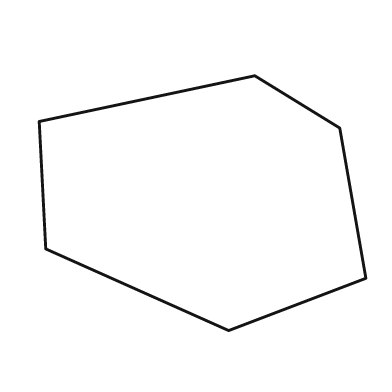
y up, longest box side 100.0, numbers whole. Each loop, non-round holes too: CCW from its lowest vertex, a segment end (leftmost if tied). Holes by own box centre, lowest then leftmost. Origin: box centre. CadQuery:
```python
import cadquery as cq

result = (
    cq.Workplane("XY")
    .moveTo(8.0, -39.0)
    .lineTo(50.0, -23.0)
    .lineTo(42.0, 23.0)
    .lineTo(16.0, 39.0)
    .lineTo(-50.0, 25.0)
    .lineTo(-48.0, -14.0)
    .close()
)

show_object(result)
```